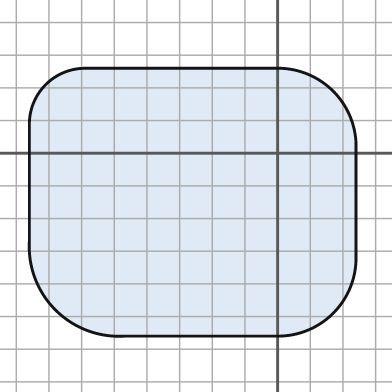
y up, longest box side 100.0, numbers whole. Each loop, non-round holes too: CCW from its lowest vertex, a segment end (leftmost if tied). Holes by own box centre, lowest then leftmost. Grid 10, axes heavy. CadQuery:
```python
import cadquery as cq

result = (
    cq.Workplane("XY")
    .moveTo(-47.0, -56.0)
    .lineTo(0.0, -56.0)
    .threePointArc((17.0, -49.0), (24.0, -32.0))
    .lineTo(24.0, 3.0)
    .threePointArc((17.0, 19.0), (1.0, 26.0))
    .lineTo(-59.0, 26.0)
    .threePointArc((-71.0, 21.0), (-76.0, 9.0))
    .lineTo(-76.0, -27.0)
    .threePointArc((-68.0, -48.0), (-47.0, -56.0))
    .close()
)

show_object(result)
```